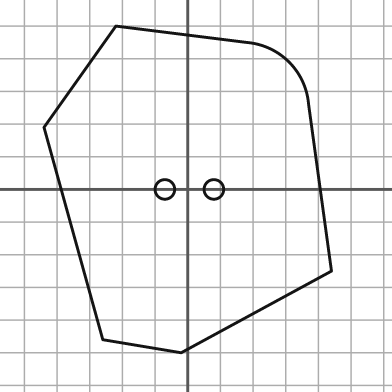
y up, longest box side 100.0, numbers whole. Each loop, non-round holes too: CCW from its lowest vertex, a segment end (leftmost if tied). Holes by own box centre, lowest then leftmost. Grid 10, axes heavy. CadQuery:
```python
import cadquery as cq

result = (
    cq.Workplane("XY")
    .moveTo(-2.0, -50.0)
    .lineTo(44.0, -25.0)
    .lineTo(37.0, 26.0)
    .threePointArc((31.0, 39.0), (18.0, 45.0))
    .lineTo(-22.0, 50.0)
    .lineTo(-44.0, 19.0)
    .lineTo(-26.0, -46.0)
    .close()
    .moveTo(-7.0, 0.0)
    .circle(3.0)
    .moveTo(8.0, 0.0)
    .circle(3.0)
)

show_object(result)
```